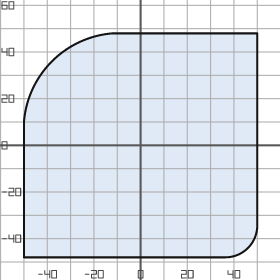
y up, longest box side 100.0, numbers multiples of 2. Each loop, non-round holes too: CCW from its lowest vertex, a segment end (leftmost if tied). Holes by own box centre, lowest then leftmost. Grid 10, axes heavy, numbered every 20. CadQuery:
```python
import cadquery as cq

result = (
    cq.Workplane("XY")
    .moveTo(-50.0, -48.0)
    .lineTo(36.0, -48.0)
    .threePointArc((46.0, -44.0), (50.0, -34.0))
    .lineTo(50.0, 48.0)
    .lineTo(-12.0, 48.0)
    .threePointArc((-38.0, 36.0), (-50.0, 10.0))
    .close()
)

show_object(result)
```